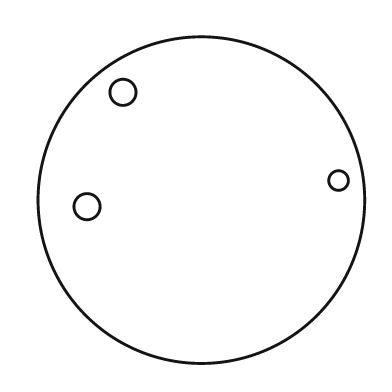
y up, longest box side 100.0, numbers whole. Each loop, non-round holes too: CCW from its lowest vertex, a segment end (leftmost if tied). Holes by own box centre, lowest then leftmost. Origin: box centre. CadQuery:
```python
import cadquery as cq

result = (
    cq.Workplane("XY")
    .moveTo(0.0, 0.0)
    .circle(50.0)
    .moveTo(-35.0, -2.0)
    .circle(4.0)
    .moveTo(42.0, 6.0)
    .circle(3.0)
    .moveTo(-24.0, 33.0)
    .circle(4.0)
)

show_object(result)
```